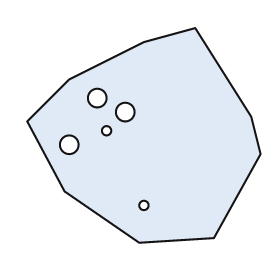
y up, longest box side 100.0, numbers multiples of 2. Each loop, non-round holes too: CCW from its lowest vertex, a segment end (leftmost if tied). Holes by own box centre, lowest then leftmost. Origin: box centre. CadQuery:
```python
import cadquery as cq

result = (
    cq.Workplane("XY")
    .moveTo(-2.0, -46.0)
    .lineTo(30.0, -44.0)
    .lineTo(50.0, -8.0)
    .lineTo(46.0, 8.0)
    .lineTo(22.0, 46.0)
    .lineTo(0.0, 40.0)
    .lineTo(-32.0, 24.0)
    .lineTo(-50.0, 6.0)
    .lineTo(-34.0, -24.0)
    .close()
    .moveTo(0.0, -30.0)
    .circle(2.0)
    .moveTo(-32.0, -4.0)
    .circle(4.0)
    .moveTo(-16.0, 2.0)
    .circle(2.0)
    .moveTo(-8.0, 10.0)
    .circle(4.0)
    .moveTo(-20.0, 16.0)
    .circle(4.0)
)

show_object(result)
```